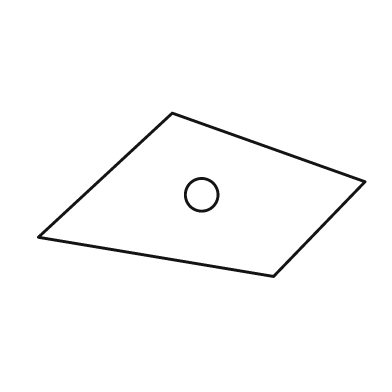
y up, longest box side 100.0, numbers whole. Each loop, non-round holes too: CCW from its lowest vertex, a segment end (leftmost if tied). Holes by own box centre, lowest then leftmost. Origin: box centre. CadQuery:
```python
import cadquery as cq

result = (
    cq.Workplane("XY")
    .moveTo(22.0, -25.0)
    .lineTo(50.0, 4.0)
    .lineTo(-9.0, 25.0)
    .lineTo(-50.0, -13.0)
    .close()
    .moveTo(0.0, 0.0)
    .circle(5.0)
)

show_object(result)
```